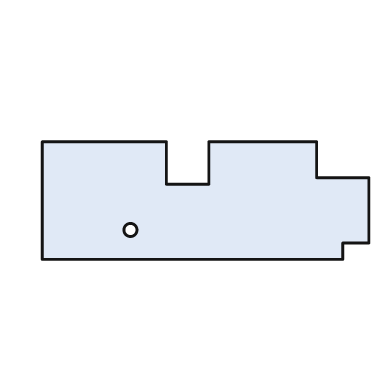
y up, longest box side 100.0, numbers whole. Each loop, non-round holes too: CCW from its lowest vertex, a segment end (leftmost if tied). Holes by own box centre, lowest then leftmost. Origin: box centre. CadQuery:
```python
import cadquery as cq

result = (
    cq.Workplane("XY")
    .moveTo(-50.0, -18.0)
    .lineTo(42.0, -18.0)
    .lineTo(42.0, -13.0)
    .lineTo(50.0, -13.0)
    .lineTo(50.0, 7.0)
    .lineTo(34.0, 7.0)
    .lineTo(34.0, 18.0)
    .lineTo(1.0, 18.0)
    .lineTo(1.0, 5.0)
    .lineTo(-12.0, 5.0)
    .lineTo(-12.0, 18.0)
    .lineTo(-50.0, 18.0)
    .close()
    .moveTo(-23.0, -9.0)
    .circle(2.0)
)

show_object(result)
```